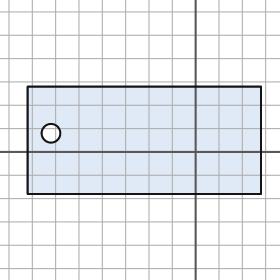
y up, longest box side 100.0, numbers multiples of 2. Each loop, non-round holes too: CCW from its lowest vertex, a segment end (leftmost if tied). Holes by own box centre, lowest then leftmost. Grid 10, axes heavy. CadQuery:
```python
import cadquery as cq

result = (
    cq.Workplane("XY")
    .moveTo(-72.0, -18.0)
    .lineTo(28.0, -18.0)
    .lineTo(28.0, 28.0)
    .lineTo(-72.0, 28.0)
    .close()
    .moveTo(-62.0, 8.0)
    .circle(4.0)
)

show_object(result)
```